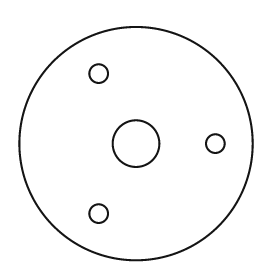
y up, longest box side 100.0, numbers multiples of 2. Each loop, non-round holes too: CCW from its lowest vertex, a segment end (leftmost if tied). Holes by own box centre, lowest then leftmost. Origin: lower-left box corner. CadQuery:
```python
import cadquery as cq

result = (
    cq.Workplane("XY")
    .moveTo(50.0, 50.0)
    .circle(50.0)
    .moveTo(34.0, 20.0)
    .circle(4.0)
    .moveTo(50.0, 50.0)
    .circle(10.0)
    .moveTo(84.0, 50.0)
    .circle(4.0)
    .moveTo(34.0, 80.0)
    .circle(4.0)
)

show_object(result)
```